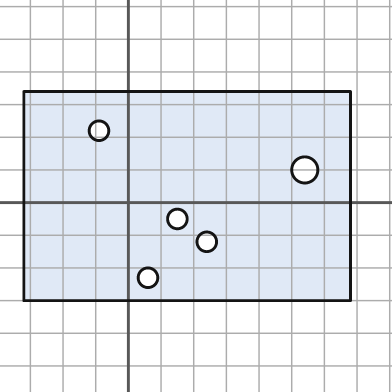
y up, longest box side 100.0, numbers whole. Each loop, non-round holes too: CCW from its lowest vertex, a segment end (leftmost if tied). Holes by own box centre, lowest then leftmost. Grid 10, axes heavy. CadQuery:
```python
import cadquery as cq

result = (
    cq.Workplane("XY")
    .moveTo(-32.0, -30.0)
    .lineTo(68.0, -30.0)
    .lineTo(68.0, 34.0)
    .lineTo(-32.0, 34.0)
    .close()
    .moveTo(6.0, -23.0)
    .circle(3.0)
    .moveTo(24.0, -12.0)
    .circle(3.0)
    .moveTo(15.0, -5.0)
    .circle(3.0)
    .moveTo(54.0, 10.0)
    .circle(4.0)
    .moveTo(-9.0, 22.0)
    .circle(3.0)
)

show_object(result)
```